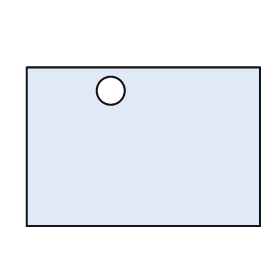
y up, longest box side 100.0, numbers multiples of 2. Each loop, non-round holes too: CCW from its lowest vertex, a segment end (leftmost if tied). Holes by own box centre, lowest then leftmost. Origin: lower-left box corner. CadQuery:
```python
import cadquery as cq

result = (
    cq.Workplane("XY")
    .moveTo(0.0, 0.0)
    .lineTo(100.0, 0.0)
    .lineTo(100.0, 68.0)
    .lineTo(0.0, 68.0)
    .close()
    .moveTo(36.0, 58.0)
    .circle(6.0)
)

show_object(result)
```